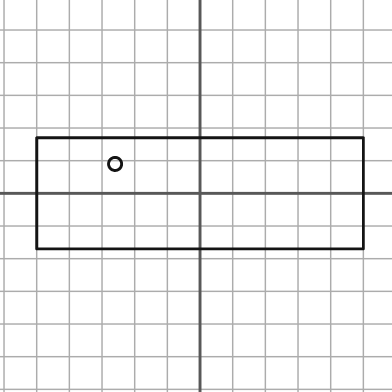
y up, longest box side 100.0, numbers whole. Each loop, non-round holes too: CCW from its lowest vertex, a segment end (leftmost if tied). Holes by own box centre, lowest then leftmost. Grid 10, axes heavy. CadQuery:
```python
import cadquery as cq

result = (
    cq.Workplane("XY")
    .moveTo(-50.0, -17.0)
    .lineTo(50.0, -17.0)
    .lineTo(50.0, 17.0)
    .lineTo(-50.0, 17.0)
    .close()
    .moveTo(-26.0, 9.0)
    .circle(2.0)
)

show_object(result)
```